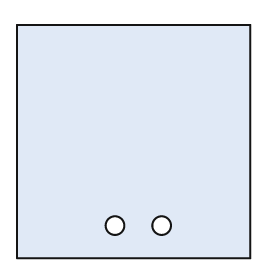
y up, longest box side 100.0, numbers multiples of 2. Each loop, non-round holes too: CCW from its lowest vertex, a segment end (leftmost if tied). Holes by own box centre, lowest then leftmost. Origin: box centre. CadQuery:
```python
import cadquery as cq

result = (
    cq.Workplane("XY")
    .moveTo(-50.0, -50.0)
    .lineTo(50.0, -50.0)
    .lineTo(50.0, 50.0)
    .lineTo(-50.0, 50.0)
    .close()
    .moveTo(-8.0, -36.0)
    .circle(4.0)
    .moveTo(12.0, -36.0)
    .circle(4.0)
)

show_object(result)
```